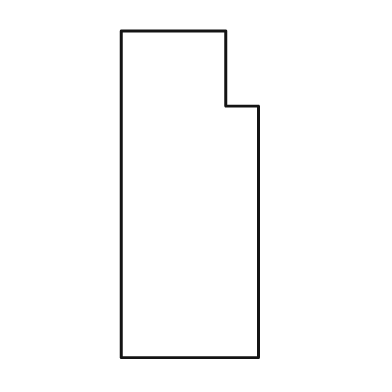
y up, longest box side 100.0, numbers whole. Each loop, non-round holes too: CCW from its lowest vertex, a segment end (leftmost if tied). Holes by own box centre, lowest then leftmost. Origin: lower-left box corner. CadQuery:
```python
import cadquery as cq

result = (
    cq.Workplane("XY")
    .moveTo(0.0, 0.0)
    .lineTo(42.0, 0.0)
    .lineTo(42.0, 77.0)
    .lineTo(32.0, 77.0)
    .lineTo(32.0, 100.0)
    .lineTo(0.0, 100.0)
    .close()
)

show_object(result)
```